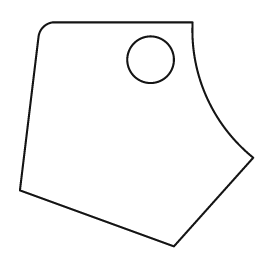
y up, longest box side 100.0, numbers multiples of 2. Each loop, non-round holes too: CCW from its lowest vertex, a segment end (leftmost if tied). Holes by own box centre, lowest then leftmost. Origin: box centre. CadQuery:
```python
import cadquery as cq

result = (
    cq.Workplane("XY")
    .moveTo(16.0, -48.0)
    .lineTo(50.0, -10.0)
    .threePointArc((30.0, 16.0), (24.0, 48.0))
    .lineTo(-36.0, 48.0)
    .threePointArc((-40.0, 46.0), (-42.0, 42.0))
    .lineTo(-50.0, -24.0)
    .close()
    .moveTo(6.0, 32.0)
    .circle(10.0)
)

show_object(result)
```